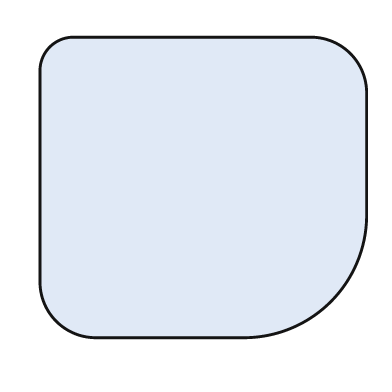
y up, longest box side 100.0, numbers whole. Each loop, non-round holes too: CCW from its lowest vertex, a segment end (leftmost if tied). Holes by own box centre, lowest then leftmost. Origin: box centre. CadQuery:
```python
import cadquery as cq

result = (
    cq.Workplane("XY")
    .moveTo(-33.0, -46.0)
    .lineTo(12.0, -46.0)
    .threePointArc((39.0, -35.0), (50.0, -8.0))
    .lineTo(50.0, 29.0)
    .threePointArc((45.0, 41.0), (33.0, 46.0))
    .lineTo(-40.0, 46.0)
    .threePointArc((-47.0, 43.0), (-50.0, 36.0))
    .lineTo(-50.0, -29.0)
    .threePointArc((-45.0, -41.0), (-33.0, -46.0))
    .close()
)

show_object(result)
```